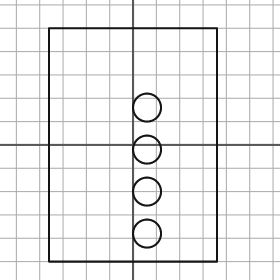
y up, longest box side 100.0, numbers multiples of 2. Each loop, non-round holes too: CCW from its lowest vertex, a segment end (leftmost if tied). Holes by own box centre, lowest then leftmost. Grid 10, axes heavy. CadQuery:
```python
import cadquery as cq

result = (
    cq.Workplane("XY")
    .moveTo(-36.0, -50.0)
    .lineTo(36.0, -50.0)
    .lineTo(36.0, 50.0)
    .lineTo(-36.0, 50.0)
    .close()
    .moveTo(6.0, -38.0)
    .circle(6.0)
    .moveTo(6.0, -20.0)
    .circle(6.0)
    .moveTo(6.0, -2.0)
    .circle(6.0)
    .moveTo(6.0, 16.0)
    .circle(6.0)
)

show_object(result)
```